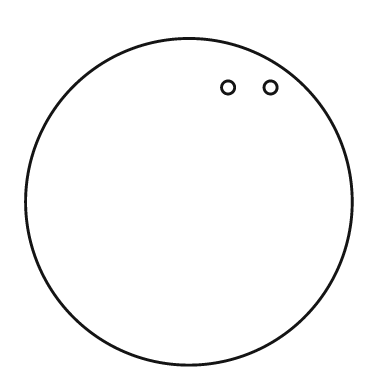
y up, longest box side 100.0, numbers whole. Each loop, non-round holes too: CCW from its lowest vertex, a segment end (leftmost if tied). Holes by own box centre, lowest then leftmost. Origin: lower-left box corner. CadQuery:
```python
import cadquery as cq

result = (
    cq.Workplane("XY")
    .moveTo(50.0, 50.0)
    .circle(50.0)
    .moveTo(62.0, 85.0)
    .circle(2.0)
    .moveTo(75.0, 85.0)
    .circle(2.0)
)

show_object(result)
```